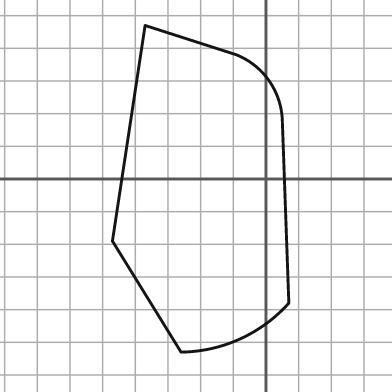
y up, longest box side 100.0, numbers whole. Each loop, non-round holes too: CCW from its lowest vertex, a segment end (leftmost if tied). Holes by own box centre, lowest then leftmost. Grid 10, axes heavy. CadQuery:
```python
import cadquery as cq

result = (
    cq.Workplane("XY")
    .moveTo(-26.0, -53.0)
    .threePointArc((-8.0, -49.0), (7.0, -38.0))
    .lineTo(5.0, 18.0)
    .threePointArc((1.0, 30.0), (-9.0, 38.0))
    .lineTo(-37.0, 47.0)
    .lineTo(-47.0, -19.0)
    .close()
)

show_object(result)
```